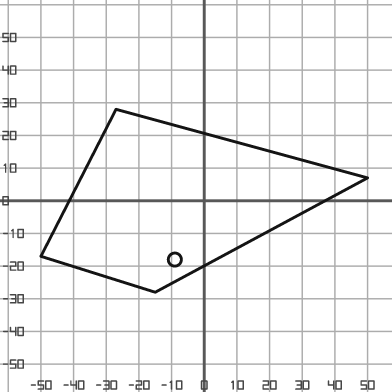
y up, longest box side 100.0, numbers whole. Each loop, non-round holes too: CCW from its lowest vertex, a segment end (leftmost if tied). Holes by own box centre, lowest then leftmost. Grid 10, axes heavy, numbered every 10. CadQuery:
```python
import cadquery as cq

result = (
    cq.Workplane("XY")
    .moveTo(-15.0, -28.0)
    .lineTo(50.0, 7.0)
    .lineTo(-27.0, 28.0)
    .lineTo(-50.0, -17.0)
    .close()
    .moveTo(-9.0, -18.0)
    .circle(2.0)
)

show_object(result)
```